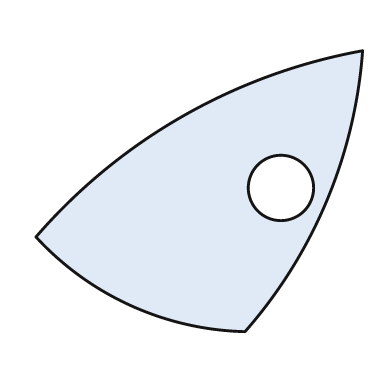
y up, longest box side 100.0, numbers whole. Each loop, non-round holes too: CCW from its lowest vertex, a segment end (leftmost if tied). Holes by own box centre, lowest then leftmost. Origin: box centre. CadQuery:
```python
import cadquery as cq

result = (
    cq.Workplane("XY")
    .moveTo(14.0, -43.0)
    .threePointArc((39.0, -3.0), (50.0, 43.0))
    .threePointArc((-5.0, 23.0), (-50.0, -14.0))
    .threePointArc((-21.0, -35.0), (14.0, -43.0))
    .close()
    .moveTo(25.0, 1.0)
    .circle(10.0)
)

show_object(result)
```